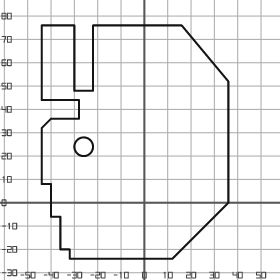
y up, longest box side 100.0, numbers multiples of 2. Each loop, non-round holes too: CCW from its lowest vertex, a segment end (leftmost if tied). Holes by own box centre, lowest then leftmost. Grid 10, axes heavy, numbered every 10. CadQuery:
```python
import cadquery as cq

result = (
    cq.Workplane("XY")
    .moveTo(-32.0, -24.0)
    .lineTo(12.0, -24.0)
    .lineTo(36.0, 0.0)
    .lineTo(36.0, 52.0)
    .lineTo(16.0, 76.0)
    .lineTo(-22.0, 76.0)
    .lineTo(-22.0, 48.0)
    .lineTo(-30.0, 48.0)
    .lineTo(-30.0, 76.0)
    .lineTo(-44.0, 76.0)
    .lineTo(-44.0, 44.0)
    .lineTo(-28.0, 44.0)
    .lineTo(-28.0, 36.0)
    .lineTo(-40.0, 36.0)
    .lineTo(-44.0, 32.0)
    .lineTo(-44.0, 8.0)
    .lineTo(-40.0, 8.0)
    .lineTo(-40.0, -6.0)
    .lineTo(-36.0, -6.0)
    .lineTo(-36.0, -20.0)
    .lineTo(-32.0, -20.0)
    .close()
    .moveTo(-26.0, 24.0)
    .circle(4.0)
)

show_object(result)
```